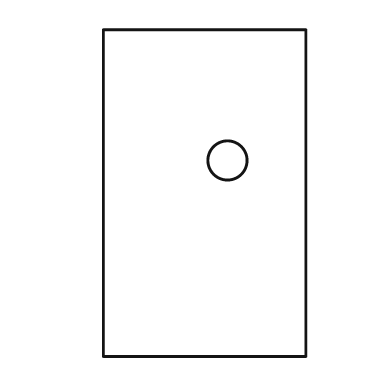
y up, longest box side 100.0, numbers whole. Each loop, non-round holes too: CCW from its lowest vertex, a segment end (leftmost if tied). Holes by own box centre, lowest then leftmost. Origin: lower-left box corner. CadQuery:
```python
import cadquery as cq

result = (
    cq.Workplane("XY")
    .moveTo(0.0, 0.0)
    .lineTo(62.0, 0.0)
    .lineTo(62.0, 100.0)
    .lineTo(0.0, 100.0)
    .close()
    .moveTo(38.0, 60.0)
    .circle(6.0)
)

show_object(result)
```